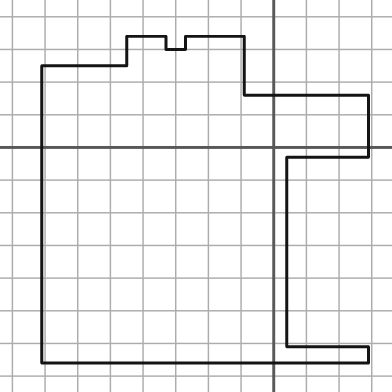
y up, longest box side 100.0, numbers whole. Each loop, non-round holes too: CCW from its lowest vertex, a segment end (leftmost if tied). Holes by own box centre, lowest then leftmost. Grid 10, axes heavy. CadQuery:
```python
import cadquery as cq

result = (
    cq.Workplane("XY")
    .moveTo(-71.0, -66.0)
    .lineTo(29.0, -66.0)
    .lineTo(29.0, -61.0)
    .lineTo(4.0, -61.0)
    .lineTo(4.0, -3.0)
    .lineTo(29.0, -3.0)
    .lineTo(29.0, 16.0)
    .lineTo(-9.0, 16.0)
    .lineTo(-9.0, 34.0)
    .lineTo(-27.0, 34.0)
    .lineTo(-27.0, 30.0)
    .lineTo(-33.0, 30.0)
    .lineTo(-33.0, 34.0)
    .lineTo(-45.0, 34.0)
    .lineTo(-45.0, 25.0)
    .lineTo(-71.0, 25.0)
    .close()
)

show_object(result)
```